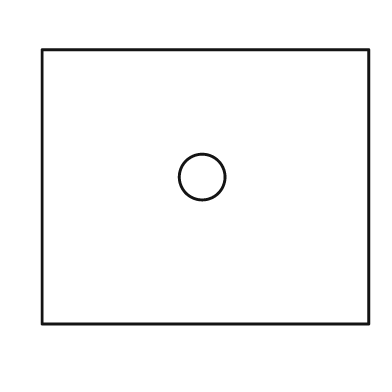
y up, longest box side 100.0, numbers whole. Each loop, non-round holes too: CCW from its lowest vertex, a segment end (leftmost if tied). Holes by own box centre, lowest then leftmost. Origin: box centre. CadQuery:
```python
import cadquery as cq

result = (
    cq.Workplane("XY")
    .moveTo(-50.0, -42.0)
    .lineTo(50.0, -42.0)
    .lineTo(50.0, 42.0)
    .lineTo(-50.0, 42.0)
    .close()
    .moveTo(-1.0, 3.0)
    .circle(7.0)
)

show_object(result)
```